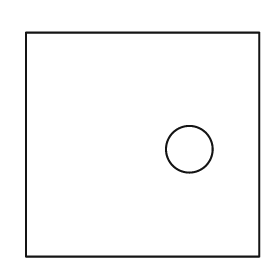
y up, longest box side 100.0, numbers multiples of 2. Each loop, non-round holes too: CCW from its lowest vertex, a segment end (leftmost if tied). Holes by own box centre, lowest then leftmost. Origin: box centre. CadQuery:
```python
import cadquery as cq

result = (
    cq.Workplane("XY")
    .moveTo(-50.0, -48.0)
    .lineTo(50.0, -48.0)
    .lineTo(50.0, 48.0)
    .lineTo(-50.0, 48.0)
    .close()
    .moveTo(20.0, -2.0)
    .circle(10.0)
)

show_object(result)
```